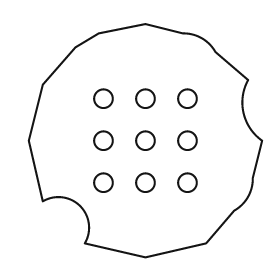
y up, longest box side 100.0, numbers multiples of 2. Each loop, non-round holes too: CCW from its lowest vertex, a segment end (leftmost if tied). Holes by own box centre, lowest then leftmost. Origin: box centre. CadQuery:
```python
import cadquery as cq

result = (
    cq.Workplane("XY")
    .moveTo(0.0, -50.0)
    .lineTo(26.0, -44.0)
    .lineTo(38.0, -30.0)
    .threePointArc((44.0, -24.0), (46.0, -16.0))
    .lineTo(50.0, 0.0)
    .threePointArc((42.0, 12.0), (44.0, 26.0))
    .lineTo(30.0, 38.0)
    .threePointArc((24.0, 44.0), (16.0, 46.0))
    .lineTo(0.0, 50.0)
    .lineTo(-20.0, 46.0)
    .lineTo(-30.0, 40.0)
    .lineTo(-44.0, 24.0)
    .lineTo(-50.0, 0.0)
    .lineTo(-44.0, -26.0)
    .threePointArc((-28.0, -28.0), (-26.0, -44.0))
    .close()
    .moveTo(-18.0, -18.0)
    .circle(4.0)
    .moveTo(0.0, -18.0)
    .circle(4.0)
    .moveTo(18.0, -18.0)
    .circle(4.0)
    .moveTo(-18.0, 0.0)
    .circle(4.0)
    .moveTo(0.0, 0.0)
    .circle(4.0)
    .moveTo(18.0, 0.0)
    .circle(4.0)
    .moveTo(-18.0, 18.0)
    .circle(4.0)
    .moveTo(0.0, 18.0)
    .circle(4.0)
    .moveTo(18.0, 18.0)
    .circle(4.0)
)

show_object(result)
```